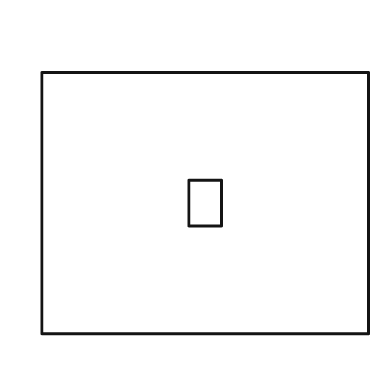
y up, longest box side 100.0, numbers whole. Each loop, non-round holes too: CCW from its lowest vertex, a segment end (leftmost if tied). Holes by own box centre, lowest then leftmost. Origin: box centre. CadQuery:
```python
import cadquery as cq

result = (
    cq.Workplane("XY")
    .moveTo(-50.0, -40.0)
    .lineTo(50.0, -40.0)
    .lineTo(50.0, 40.0)
    .lineTo(-50.0, 40.0)
    .close()
    .moveTo(-5.0, -7.0)
    .lineTo(5.0, -7.0)
    .lineTo(5.0, 7.0)
    .lineTo(-5.0, 7.0)
    .close()
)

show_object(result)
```